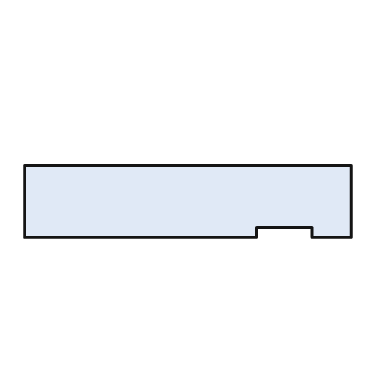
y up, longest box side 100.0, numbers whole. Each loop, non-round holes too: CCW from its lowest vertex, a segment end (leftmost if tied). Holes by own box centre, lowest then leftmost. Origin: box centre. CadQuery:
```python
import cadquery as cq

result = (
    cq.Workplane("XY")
    .moveTo(-50.0, -11.0)
    .lineTo(21.0, -11.0)
    .lineTo(21.0, -8.0)
    .lineTo(38.0, -8.0)
    .lineTo(38.0, -11.0)
    .lineTo(50.0, -11.0)
    .lineTo(50.0, 11.0)
    .lineTo(-50.0, 11.0)
    .close()
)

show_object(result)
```